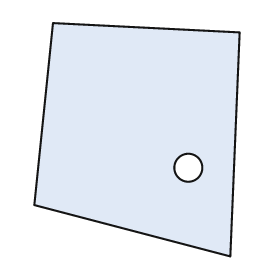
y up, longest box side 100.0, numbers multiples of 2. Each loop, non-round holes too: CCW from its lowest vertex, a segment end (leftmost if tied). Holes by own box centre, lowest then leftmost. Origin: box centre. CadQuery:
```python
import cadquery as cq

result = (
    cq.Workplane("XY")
    .moveTo(40.0, -50.0)
    .lineTo(44.0, 46.0)
    .lineTo(-36.0, 50.0)
    .lineTo(-44.0, -28.0)
    .close()
    .moveTo(22.0, -12.0)
    .circle(6.0)
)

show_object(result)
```